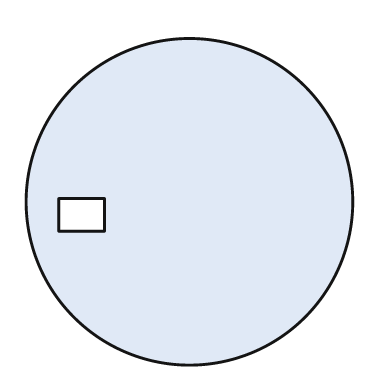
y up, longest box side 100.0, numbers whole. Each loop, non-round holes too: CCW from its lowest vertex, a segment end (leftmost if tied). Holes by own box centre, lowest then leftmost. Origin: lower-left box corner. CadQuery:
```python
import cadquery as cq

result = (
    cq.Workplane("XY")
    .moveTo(50.0, 50.0)
    .circle(50.0)
    .moveTo(10.0, 41.0)
    .lineTo(24.0, 41.0)
    .lineTo(24.0, 51.0)
    .lineTo(10.0, 51.0)
    .close()
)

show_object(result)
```